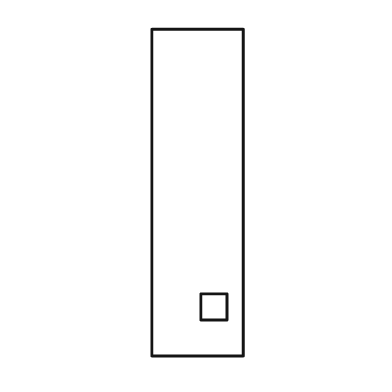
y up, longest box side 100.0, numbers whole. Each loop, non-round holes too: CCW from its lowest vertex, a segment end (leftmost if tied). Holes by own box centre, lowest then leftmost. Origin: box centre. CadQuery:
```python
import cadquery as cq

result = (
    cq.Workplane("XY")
    .moveTo(-14.0, -50.0)
    .lineTo(14.0, -50.0)
    .lineTo(14.0, 50.0)
    .lineTo(-14.0, 50.0)
    .close()
    .moveTo(1.0, -39.0)
    .lineTo(9.0, -39.0)
    .lineTo(9.0, -31.0)
    .lineTo(1.0, -31.0)
    .close()
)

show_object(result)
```